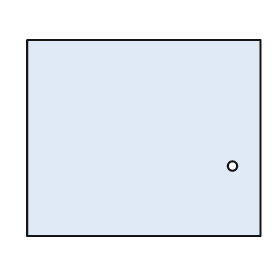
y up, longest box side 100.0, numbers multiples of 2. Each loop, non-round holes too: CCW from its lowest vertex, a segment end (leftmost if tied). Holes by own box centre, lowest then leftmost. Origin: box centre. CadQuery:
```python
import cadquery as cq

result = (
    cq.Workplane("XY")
    .moveTo(-50.0, -42.0)
    .lineTo(50.0, -42.0)
    .lineTo(50.0, 42.0)
    .lineTo(-50.0, 42.0)
    .close()
    .moveTo(38.0, -12.0)
    .circle(2.0)
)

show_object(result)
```